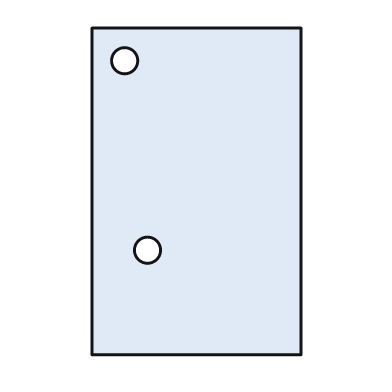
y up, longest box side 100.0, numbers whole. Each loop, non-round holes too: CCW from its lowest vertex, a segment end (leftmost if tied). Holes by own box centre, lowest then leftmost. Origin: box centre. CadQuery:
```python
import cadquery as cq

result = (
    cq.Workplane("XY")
    .moveTo(-32.0, -50.0)
    .lineTo(32.0, -50.0)
    .lineTo(32.0, 50.0)
    .lineTo(-32.0, 50.0)
    .close()
    .moveTo(-15.0, -18.0)
    .circle(4.0)
    .moveTo(-22.0, 40.0)
    .circle(4.0)
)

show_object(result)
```